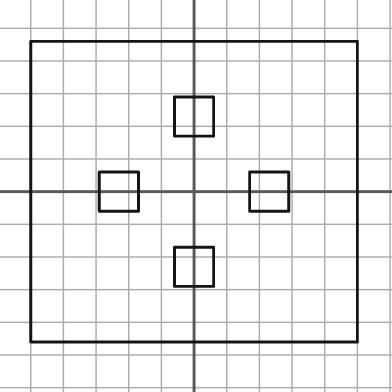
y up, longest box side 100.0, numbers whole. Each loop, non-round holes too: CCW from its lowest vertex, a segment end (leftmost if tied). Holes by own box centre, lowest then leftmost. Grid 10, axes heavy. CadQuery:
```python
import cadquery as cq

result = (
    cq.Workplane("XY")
    .moveTo(-50.0, -46.0)
    .lineTo(50.0, -46.0)
    .lineTo(50.0, 46.0)
    .lineTo(-50.0, 46.0)
    .close()
    .moveTo(-6.0, -29.0)
    .lineTo(6.0, -29.0)
    .lineTo(6.0, -17.0)
    .lineTo(-6.0, -17.0)
    .close()
    .moveTo(-29.0, -6.0)
    .lineTo(-17.0, -6.0)
    .lineTo(-17.0, 6.0)
    .lineTo(-29.0, 6.0)
    .close()
    .moveTo(17.0, -6.0)
    .lineTo(29.0, -6.0)
    .lineTo(29.0, 6.0)
    .lineTo(17.0, 6.0)
    .close()
    .moveTo(-6.0, 17.0)
    .lineTo(6.0, 17.0)
    .lineTo(6.0, 29.0)
    .lineTo(-6.0, 29.0)
    .close()
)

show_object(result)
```